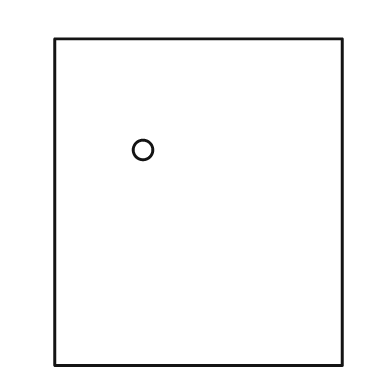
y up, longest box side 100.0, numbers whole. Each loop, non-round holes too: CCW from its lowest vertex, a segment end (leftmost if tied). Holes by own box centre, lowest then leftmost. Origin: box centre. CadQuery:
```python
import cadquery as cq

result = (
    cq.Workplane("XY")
    .moveTo(-44.0, -50.0)
    .lineTo(44.0, -50.0)
    .lineTo(44.0, 50.0)
    .lineTo(-44.0, 50.0)
    .close()
    .moveTo(-17.0, 16.0)
    .circle(3.0)
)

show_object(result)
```